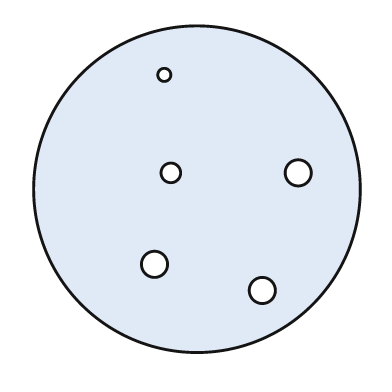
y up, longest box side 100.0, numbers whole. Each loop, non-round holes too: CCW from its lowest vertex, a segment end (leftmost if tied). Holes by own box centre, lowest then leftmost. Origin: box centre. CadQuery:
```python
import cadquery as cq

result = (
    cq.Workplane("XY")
    .moveTo(0.0, 0.0)
    .circle(50.0)
    .moveTo(20.0, -31.0)
    .circle(4.0)
    .moveTo(-13.0, -23.0)
    .circle(4.0)
    .moveTo(-8.0, 5.0)
    .circle(3.0)
    .moveTo(31.0, 5.0)
    .circle(4.0)
    .moveTo(-10.0, 35.0)
    .circle(2.0)
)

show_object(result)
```